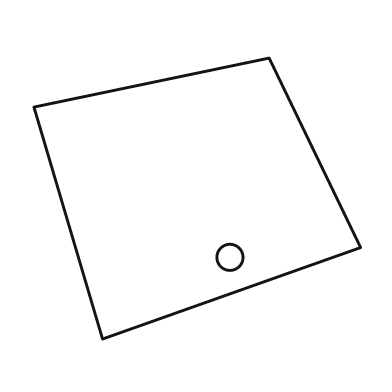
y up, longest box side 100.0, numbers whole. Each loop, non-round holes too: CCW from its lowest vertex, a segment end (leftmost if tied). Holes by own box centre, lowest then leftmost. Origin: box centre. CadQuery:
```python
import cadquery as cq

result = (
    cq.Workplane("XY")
    .moveTo(-29.0, -43.0)
    .lineTo(50.0, -15.0)
    .lineTo(22.0, 43.0)
    .lineTo(-50.0, 28.0)
    .close()
    .moveTo(10.0, -18.0)
    .circle(4.0)
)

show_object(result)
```